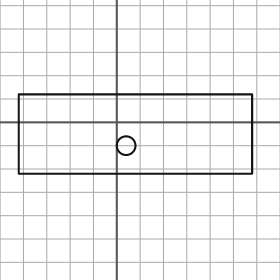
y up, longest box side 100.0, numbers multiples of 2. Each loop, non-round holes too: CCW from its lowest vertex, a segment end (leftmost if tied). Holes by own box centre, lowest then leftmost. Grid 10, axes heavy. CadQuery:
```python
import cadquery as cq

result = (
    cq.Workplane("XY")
    .moveTo(-42.0, -22.0)
    .lineTo(58.0, -22.0)
    .lineTo(58.0, 12.0)
    .lineTo(-42.0, 12.0)
    .close()
    .moveTo(4.0, -10.0)
    .circle(4.0)
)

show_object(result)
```